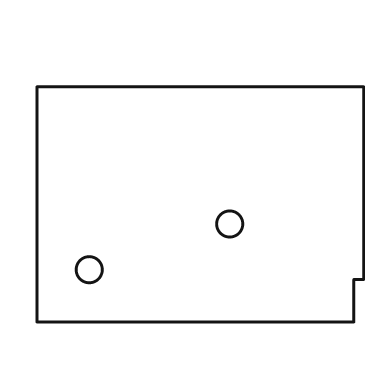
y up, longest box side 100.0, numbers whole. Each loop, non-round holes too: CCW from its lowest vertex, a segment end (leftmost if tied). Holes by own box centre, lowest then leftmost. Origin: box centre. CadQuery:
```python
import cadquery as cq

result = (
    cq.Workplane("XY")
    .moveTo(-50.0, -36.0)
    .lineTo(47.0, -36.0)
    .lineTo(47.0, -23.0)
    .lineTo(50.0, -23.0)
    .lineTo(50.0, 36.0)
    .lineTo(-50.0, 36.0)
    .close()
    .moveTo(-34.0, -20.0)
    .circle(4.0)
    .moveTo(9.0, -6.0)
    .circle(4.0)
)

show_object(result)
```